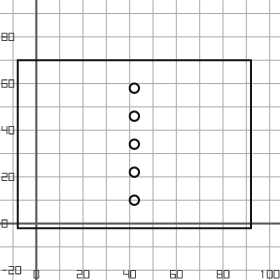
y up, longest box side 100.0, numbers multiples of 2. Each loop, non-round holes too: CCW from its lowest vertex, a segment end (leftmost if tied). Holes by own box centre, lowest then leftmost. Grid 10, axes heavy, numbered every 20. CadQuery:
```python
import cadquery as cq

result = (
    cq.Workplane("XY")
    .moveTo(-8.0, -2.0)
    .lineTo(92.0, -2.0)
    .lineTo(92.0, 70.0)
    .lineTo(-8.0, 70.0)
    .close()
    .moveTo(42.0, 10.0)
    .circle(2.0)
    .moveTo(42.0, 22.0)
    .circle(2.0)
    .moveTo(42.0, 34.0)
    .circle(2.0)
    .moveTo(42.0, 46.0)
    .circle(2.0)
    .moveTo(42.0, 58.0)
    .circle(2.0)
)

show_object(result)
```